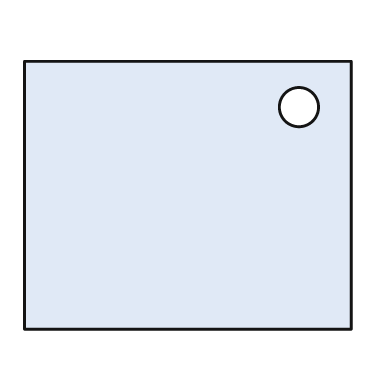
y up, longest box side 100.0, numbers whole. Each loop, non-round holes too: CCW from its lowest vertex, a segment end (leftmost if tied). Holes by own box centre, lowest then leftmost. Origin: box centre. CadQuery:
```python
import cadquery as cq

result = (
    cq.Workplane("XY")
    .moveTo(-50.0, -41.0)
    .lineTo(50.0, -41.0)
    .lineTo(50.0, 41.0)
    .lineTo(-50.0, 41.0)
    .close()
    .moveTo(34.0, 27.0)
    .circle(6.0)
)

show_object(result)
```